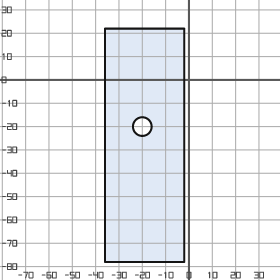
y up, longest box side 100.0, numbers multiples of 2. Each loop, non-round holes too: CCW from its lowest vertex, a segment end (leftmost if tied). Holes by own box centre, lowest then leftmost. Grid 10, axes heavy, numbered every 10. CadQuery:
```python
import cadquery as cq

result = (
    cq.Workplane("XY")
    .moveTo(-36.0, -78.0)
    .lineTo(-2.0, -78.0)
    .lineTo(-2.0, 22.0)
    .lineTo(-36.0, 22.0)
    .close()
    .moveTo(-20.0, -20.0)
    .circle(4.0)
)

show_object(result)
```